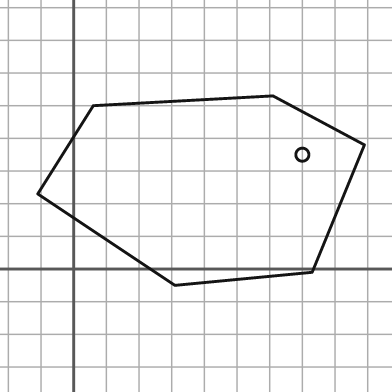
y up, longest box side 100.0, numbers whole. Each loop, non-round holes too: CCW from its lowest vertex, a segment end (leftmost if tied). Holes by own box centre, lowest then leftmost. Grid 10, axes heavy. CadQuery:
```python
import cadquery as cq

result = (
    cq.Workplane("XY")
    .moveTo(31.0, -5.0)
    .lineTo(73.0, -1.0)
    .lineTo(89.0, 38.0)
    .lineTo(61.0, 53.0)
    .lineTo(6.0, 50.0)
    .lineTo(-11.0, 23.0)
    .close()
    .moveTo(70.0, 35.0)
    .circle(2.0)
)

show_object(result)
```